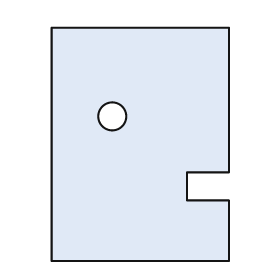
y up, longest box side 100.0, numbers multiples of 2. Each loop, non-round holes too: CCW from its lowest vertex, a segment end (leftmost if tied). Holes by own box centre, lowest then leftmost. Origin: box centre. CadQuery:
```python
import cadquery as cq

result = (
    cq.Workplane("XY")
    .moveTo(-38.0, -50.0)
    .lineTo(38.0, -50.0)
    .lineTo(38.0, -24.0)
    .lineTo(20.0, -24.0)
    .lineTo(20.0, -12.0)
    .lineTo(38.0, -12.0)
    .lineTo(38.0, 50.0)
    .lineTo(-38.0, 50.0)
    .close()
    .moveTo(-12.0, 12.0)
    .circle(6.0)
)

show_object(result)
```